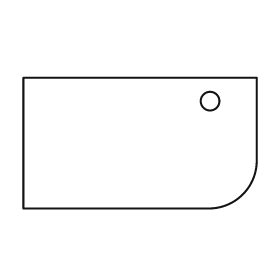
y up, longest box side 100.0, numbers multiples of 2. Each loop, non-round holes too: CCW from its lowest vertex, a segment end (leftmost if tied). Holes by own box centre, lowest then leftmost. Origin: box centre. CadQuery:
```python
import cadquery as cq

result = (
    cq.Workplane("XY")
    .moveTo(-50.0, -28.0)
    .lineTo(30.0, -28.0)
    .threePointArc((44.0, -22.0), (50.0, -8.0))
    .lineTo(50.0, 28.0)
    .lineTo(-50.0, 28.0)
    .close()
    .moveTo(30.0, 18.0)
    .circle(4.0)
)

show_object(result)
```